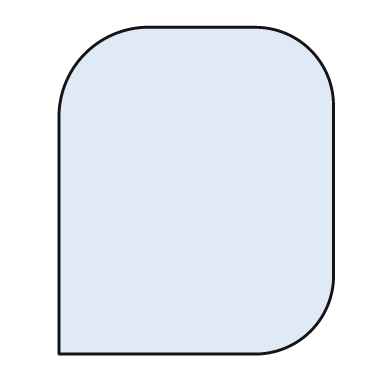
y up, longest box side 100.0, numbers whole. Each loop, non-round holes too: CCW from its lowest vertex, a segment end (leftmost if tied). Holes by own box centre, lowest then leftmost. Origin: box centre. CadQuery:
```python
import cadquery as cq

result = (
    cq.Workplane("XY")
    .moveTo(-42.0, -50.0)
    .lineTo(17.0, -50.0)
    .threePointArc((35.0, -43.0), (42.0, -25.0))
    .lineTo(42.0, 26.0)
    .threePointArc((35.0, 43.0), (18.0, 50.0))
    .lineTo(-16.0, 50.0)
    .threePointArc((-34.0, 42.0), (-42.0, 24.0))
    .close()
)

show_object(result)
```